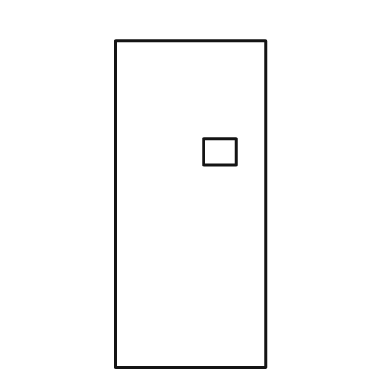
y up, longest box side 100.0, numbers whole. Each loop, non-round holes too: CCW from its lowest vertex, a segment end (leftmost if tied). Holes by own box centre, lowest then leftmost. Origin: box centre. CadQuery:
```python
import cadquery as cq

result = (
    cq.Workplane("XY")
    .moveTo(-23.0, -50.0)
    .lineTo(23.0, -50.0)
    .lineTo(23.0, 50.0)
    .lineTo(-23.0, 50.0)
    .close()
    .moveTo(4.0, 12.0)
    .lineTo(14.0, 12.0)
    .lineTo(14.0, 20.0)
    .lineTo(4.0, 20.0)
    .close()
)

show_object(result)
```